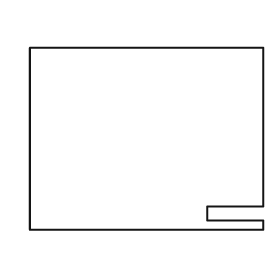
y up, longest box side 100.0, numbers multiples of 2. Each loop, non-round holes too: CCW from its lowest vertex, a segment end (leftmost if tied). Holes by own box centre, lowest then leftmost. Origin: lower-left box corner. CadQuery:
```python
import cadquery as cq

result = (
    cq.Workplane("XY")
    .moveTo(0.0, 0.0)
    .lineTo(100.0, 0.0)
    .lineTo(100.0, 4.0)
    .lineTo(76.0, 4.0)
    .lineTo(76.0, 10.0)
    .lineTo(100.0, 10.0)
    .lineTo(100.0, 78.0)
    .lineTo(0.0, 78.0)
    .close()
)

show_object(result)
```